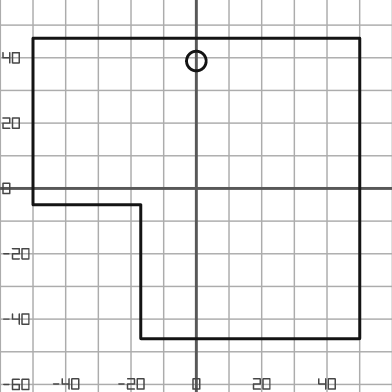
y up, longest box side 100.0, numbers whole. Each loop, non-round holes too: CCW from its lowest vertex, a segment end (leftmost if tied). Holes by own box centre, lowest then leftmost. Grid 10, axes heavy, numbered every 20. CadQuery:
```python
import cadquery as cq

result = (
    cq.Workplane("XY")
    .moveTo(-17.0, -46.0)
    .lineTo(50.0, -46.0)
    .lineTo(50.0, 46.0)
    .lineTo(-50.0, 46.0)
    .lineTo(-50.0, -5.0)
    .lineTo(-17.0, -5.0)
    .close()
    .moveTo(0.0, 39.0)
    .circle(3.0)
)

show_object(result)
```